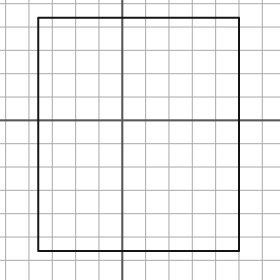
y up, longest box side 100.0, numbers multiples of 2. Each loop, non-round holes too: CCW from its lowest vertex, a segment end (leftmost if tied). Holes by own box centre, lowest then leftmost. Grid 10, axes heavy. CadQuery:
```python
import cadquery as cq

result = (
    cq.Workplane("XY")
    .moveTo(-36.0, -56.0)
    .lineTo(50.0, -56.0)
    .lineTo(50.0, 44.0)
    .lineTo(-36.0, 44.0)
    .close()
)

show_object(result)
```